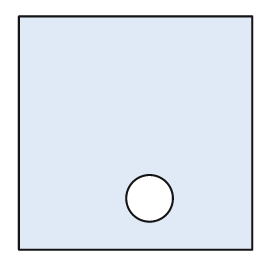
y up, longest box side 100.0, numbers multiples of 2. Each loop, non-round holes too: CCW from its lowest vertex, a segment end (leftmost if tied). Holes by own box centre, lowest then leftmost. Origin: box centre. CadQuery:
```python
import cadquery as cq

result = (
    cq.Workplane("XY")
    .moveTo(-50.0, -50.0)
    .lineTo(50.0, -50.0)
    .lineTo(50.0, 50.0)
    .lineTo(-50.0, 50.0)
    .close()
    .moveTo(6.0, -28.0)
    .circle(10.0)
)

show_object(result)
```